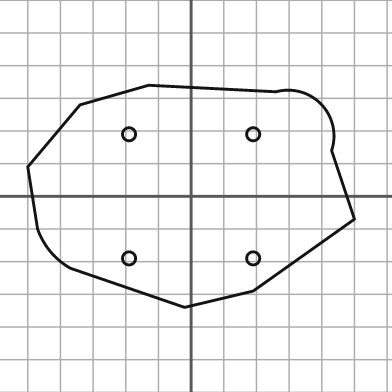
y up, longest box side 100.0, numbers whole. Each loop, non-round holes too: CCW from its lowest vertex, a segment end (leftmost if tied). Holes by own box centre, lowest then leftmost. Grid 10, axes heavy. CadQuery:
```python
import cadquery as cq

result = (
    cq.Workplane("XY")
    .moveTo(-2.0, -34.0)
    .lineTo(19.0, -29.0)
    .lineTo(50.0, -7.0)
    .lineTo(43.0, 14.0)
    .threePointArc((40.0, 28.0), (26.0, 32.0))
    .lineTo(-13.0, 34.0)
    .lineTo(-34.0, 28.0)
    .lineTo(-50.0, 9.0)
    .lineTo(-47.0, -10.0)
    .threePointArc((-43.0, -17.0), (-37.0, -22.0))
    .close()
    .moveTo(-19.0, -19.0)
    .circle(2.0)
    .moveTo(19.0, -19.0)
    .circle(2.0)
    .moveTo(-19.0, 19.0)
    .circle(2.0)
    .moveTo(19.0, 19.0)
    .circle(2.0)
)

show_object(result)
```